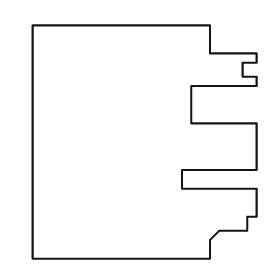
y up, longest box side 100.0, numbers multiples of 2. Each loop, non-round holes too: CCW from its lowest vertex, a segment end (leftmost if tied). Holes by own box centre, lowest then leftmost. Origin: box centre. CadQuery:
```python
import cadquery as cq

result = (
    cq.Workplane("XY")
    .moveTo(-48.0, -50.0)
    .lineTo(28.0, -50.0)
    .lineTo(28.0, -42.0)
    .lineTo(32.0, -38.0)
    .lineTo(44.0, -38.0)
    .lineTo(44.0, -32.0)
    .lineTo(48.0, -32.0)
    .lineTo(48.0, -20.0)
    .lineTo(16.0, -20.0)
    .lineTo(16.0, -12.0)
    .lineTo(48.0, -12.0)
    .lineTo(48.0, 8.0)
    .lineTo(20.0, 8.0)
    .lineTo(20.0, 24.0)
    .lineTo(48.0, 24.0)
    .lineTo(48.0, 28.0)
    .lineTo(42.0, 28.0)
    .lineTo(42.0, 34.0)
    .lineTo(48.0, 34.0)
    .lineTo(48.0, 38.0)
    .lineTo(28.0, 38.0)
    .lineTo(28.0, 50.0)
    .lineTo(-48.0, 50.0)
    .close()
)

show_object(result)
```